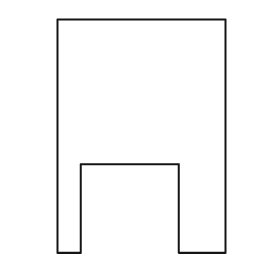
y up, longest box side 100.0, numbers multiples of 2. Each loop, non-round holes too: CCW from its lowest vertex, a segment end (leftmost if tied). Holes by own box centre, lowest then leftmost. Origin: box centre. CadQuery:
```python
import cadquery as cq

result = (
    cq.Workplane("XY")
    .moveTo(-36.0, -50.0)
    .lineTo(-26.0, -50.0)
    .lineTo(-26.0, -12.0)
    .lineTo(16.0, -12.0)
    .lineTo(16.0, -50.0)
    .lineTo(36.0, -50.0)
    .lineTo(36.0, 50.0)
    .lineTo(-36.0, 50.0)
    .close()
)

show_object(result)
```